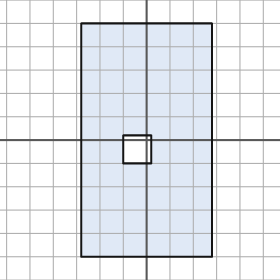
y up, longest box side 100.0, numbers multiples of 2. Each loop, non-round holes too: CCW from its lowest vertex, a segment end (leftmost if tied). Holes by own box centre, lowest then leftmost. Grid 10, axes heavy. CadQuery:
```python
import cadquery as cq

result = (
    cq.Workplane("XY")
    .moveTo(-28.0, -50.0)
    .lineTo(28.0, -50.0)
    .lineTo(28.0, 50.0)
    .lineTo(-28.0, 50.0)
    .close()
    .moveTo(-10.0, -10.0)
    .lineTo(2.0, -10.0)
    .lineTo(2.0, 2.0)
    .lineTo(-10.0, 2.0)
    .close()
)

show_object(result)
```